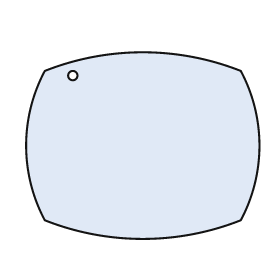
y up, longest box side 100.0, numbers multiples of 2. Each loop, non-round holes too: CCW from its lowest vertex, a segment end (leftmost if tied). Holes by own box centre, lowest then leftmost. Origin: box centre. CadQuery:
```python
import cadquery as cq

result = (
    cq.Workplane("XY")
    .moveTo(-42.0, -32.0)
    .threePointArc((0.0, -40.0), (42.0, -32.0))
    .threePointArc((50.0, 0.0), (42.0, 32.0))
    .threePointArc((0.0, 40.0), (-42.0, 32.0))
    .threePointArc((-50.0, 0.0), (-42.0, -32.0))
    .close()
    .moveTo(-30.0, 30.0)
    .circle(2.0)
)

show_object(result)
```